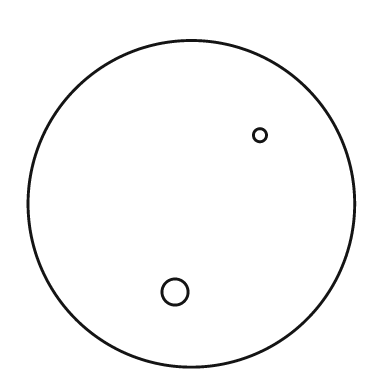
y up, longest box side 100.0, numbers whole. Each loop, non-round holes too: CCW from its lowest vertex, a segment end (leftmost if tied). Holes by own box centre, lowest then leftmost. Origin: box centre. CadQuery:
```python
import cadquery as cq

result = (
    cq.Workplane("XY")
    .moveTo(0.0, 0.0)
    .circle(50.0)
    .moveTo(-5.0, -27.0)
    .circle(4.0)
    .moveTo(21.0, 21.0)
    .circle(2.0)
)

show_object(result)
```